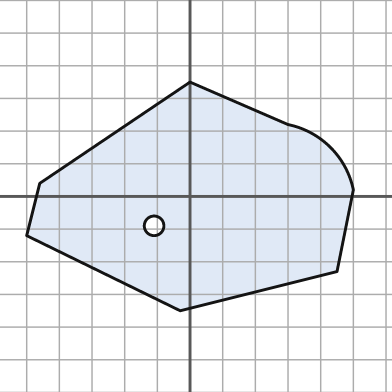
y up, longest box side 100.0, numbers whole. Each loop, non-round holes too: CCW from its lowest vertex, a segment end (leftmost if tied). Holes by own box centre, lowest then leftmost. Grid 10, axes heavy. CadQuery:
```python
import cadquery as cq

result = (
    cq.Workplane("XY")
    .moveTo(-3.0, -35.0)
    .lineTo(45.0, -23.0)
    .lineTo(50.0, 2.0)
    .threePointArc((43.0, 15.0), (30.0, 22.0))
    .lineTo(0.0, 35.0)
    .lineTo(-46.0, 4.0)
    .lineTo(-50.0, -12.0)
    .close()
    .moveTo(-11.0, -9.0)
    .circle(3.0)
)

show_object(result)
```